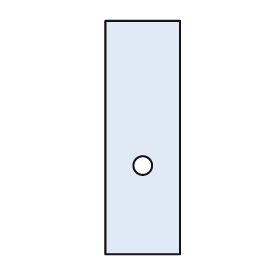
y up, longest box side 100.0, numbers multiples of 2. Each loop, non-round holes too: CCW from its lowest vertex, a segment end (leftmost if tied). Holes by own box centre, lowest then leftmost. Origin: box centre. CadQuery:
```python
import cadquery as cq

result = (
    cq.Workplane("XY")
    .moveTo(-16.0, -50.0)
    .lineTo(16.0, -50.0)
    .lineTo(16.0, 50.0)
    .lineTo(-16.0, 50.0)
    .close()
    .moveTo(0.0, -12.0)
    .circle(4.0)
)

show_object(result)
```